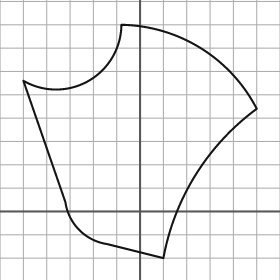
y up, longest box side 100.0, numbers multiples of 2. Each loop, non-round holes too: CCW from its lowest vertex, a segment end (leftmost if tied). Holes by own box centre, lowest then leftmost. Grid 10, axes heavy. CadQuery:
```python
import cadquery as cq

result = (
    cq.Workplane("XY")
    .moveTo(10.0, -20.0)
    .threePointArc((24.0, 16.0), (50.0, 44.0))
    .threePointArc((26.0, 70.0), (-8.0, 80.0))
    .threePointArc((-22.0, 56.0), (-50.0, 56.0))
    .lineTo(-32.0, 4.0)
    .threePointArc((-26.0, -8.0), (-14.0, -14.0))
    .close()
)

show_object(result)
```